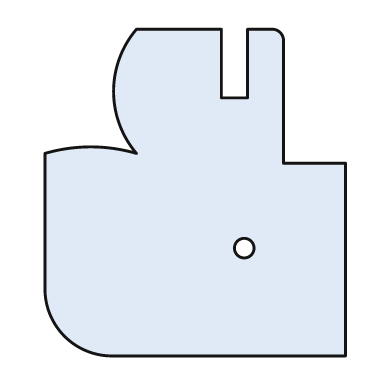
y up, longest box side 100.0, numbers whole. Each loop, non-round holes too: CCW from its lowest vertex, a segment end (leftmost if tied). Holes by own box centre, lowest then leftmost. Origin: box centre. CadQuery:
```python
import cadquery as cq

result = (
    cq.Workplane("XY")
    .moveTo(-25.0, -50.0)
    .lineTo(46.0, -50.0)
    .lineTo(46.0, 9.0)
    .lineTo(27.0, 9.0)
    .lineTo(27.0, 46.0)
    .threePointArc((26.0, 49.0), (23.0, 50.0))
    .lineTo(16.0, 50.0)
    .lineTo(16.0, 29.0)
    .lineTo(8.0, 29.0)
    .lineTo(8.0, 50.0)
    .lineTo(-18.0, 50.0)
    .threePointArc((-25.0, 31.0), (-18.0, 12.0))
    .threePointArc((-32.0, 14.0), (-46.0, 12.0))
    .lineTo(-46.0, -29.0)
    .threePointArc((-40.0, -44.0), (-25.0, -50.0))
    .close()
    .moveTo(15.0, -17.0)
    .circle(3.0)
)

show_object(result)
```